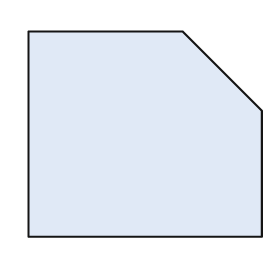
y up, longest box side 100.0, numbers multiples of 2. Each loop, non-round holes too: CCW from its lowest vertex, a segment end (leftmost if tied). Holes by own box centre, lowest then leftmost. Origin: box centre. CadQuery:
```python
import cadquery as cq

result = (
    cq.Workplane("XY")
    .moveTo(-50.0, -44.0)
    .lineTo(50.0, -44.0)
    .lineTo(50.0, 10.0)
    .lineTo(16.0, 44.0)
    .lineTo(-50.0, 44.0)
    .close()
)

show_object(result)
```